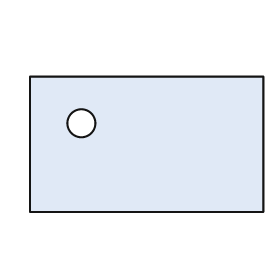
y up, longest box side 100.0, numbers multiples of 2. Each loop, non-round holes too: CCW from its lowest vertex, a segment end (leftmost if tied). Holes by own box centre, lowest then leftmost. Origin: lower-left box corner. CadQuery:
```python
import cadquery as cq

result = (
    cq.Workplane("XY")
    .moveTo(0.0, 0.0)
    .lineTo(100.0, 0.0)
    .lineTo(100.0, 58.0)
    .lineTo(0.0, 58.0)
    .close()
    .moveTo(22.0, 38.0)
    .circle(6.0)
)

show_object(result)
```